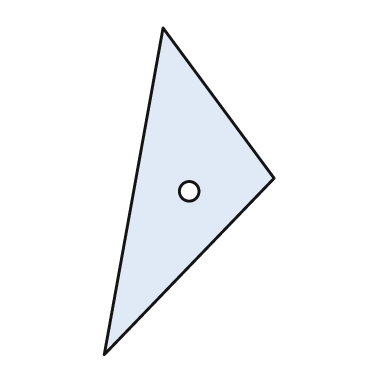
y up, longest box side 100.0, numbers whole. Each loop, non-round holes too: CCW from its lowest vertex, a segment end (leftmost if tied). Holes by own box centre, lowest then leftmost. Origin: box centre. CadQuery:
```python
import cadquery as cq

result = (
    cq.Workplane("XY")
    .moveTo(-26.0, -50.0)
    .lineTo(26.0, 4.0)
    .lineTo(-8.0, 50.0)
    .close()
    .moveTo(0.0, 0.0)
    .circle(3.0)
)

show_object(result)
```